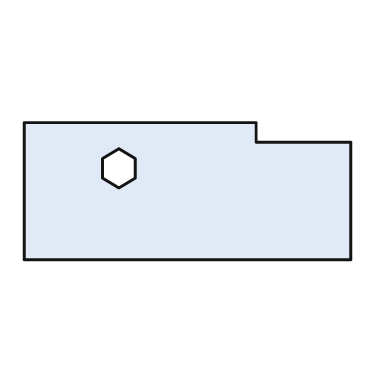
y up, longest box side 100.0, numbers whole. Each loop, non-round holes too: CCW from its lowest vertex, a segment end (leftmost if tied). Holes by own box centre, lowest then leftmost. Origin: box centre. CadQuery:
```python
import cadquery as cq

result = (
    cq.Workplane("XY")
    .moveTo(-50.0, -21.0)
    .lineTo(50.0, -21.0)
    .lineTo(50.0, 15.0)
    .lineTo(21.0, 15.0)
    .lineTo(21.0, 21.0)
    .lineTo(-50.0, 21.0)
    .close()
    .moveTo(-21.0, 1.0)
    .lineTo(-16.0, 4.0)
    .lineTo(-16.0, 10.0)
    .lineTo(-21.0, 13.0)
    .lineTo(-26.0, 10.0)
    .lineTo(-26.0, 4.0)
    .close()
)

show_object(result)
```